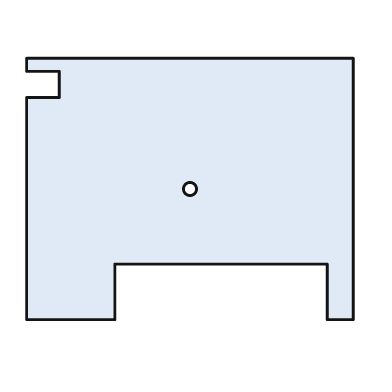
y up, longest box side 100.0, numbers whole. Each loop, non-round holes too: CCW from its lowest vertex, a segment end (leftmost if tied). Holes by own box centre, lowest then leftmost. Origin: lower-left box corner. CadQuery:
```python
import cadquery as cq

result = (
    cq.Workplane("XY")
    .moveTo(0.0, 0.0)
    .lineTo(27.0, 0.0)
    .lineTo(27.0, 17.0)
    .lineTo(92.0, 17.0)
    .lineTo(92.0, 0.0)
    .lineTo(100.0, 0.0)
    .lineTo(100.0, 80.0)
    .lineTo(0.0, 80.0)
    .lineTo(0.0, 76.0)
    .lineTo(10.0, 76.0)
    .lineTo(10.0, 68.0)
    .lineTo(0.0, 68.0)
    .close()
    .moveTo(50.0, 40.0)
    .circle(2.0)
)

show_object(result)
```